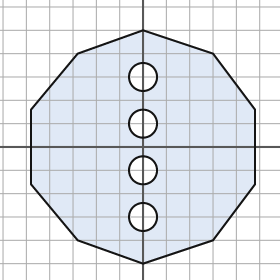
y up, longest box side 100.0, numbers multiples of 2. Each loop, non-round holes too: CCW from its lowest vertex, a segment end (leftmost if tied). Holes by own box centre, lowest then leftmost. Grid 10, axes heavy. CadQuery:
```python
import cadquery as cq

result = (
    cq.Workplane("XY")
    .moveTo(0.0, -50.0)
    .lineTo(30.0, -40.0)
    .lineTo(48.0, -16.0)
    .lineTo(48.0, 16.0)
    .lineTo(30.0, 40.0)
    .lineTo(0.0, 50.0)
    .lineTo(-28.0, 40.0)
    .lineTo(-48.0, 16.0)
    .lineTo(-48.0, -16.0)
    .lineTo(-28.0, -40.0)
    .close()
    .moveTo(0.0, -30.0)
    .circle(6.0)
    .moveTo(0.0, -10.0)
    .circle(6.0)
    .moveTo(0.0, 10.0)
    .circle(6.0)
    .moveTo(0.0, 30.0)
    .circle(6.0)
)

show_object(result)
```